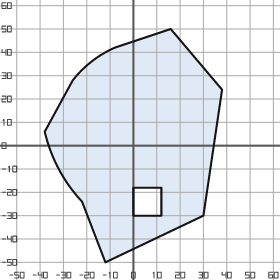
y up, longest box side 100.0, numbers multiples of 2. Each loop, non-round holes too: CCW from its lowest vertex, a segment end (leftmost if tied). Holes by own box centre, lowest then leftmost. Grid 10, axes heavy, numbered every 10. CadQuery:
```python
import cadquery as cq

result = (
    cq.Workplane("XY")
    .moveTo(-12.0, -50.0)
    .lineTo(30.0, -30.0)
    .lineTo(38.0, 24.0)
    .lineTo(16.0, 50.0)
    .lineTo(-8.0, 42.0)
    .threePointArc((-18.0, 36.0), (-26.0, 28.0))
    .lineTo(-38.0, 6.0)
    .threePointArc((-32.0, -10.0), (-22.0, -24.0))
    .close()
    .moveTo(0.0, -30.0)
    .lineTo(12.0, -30.0)
    .lineTo(12.0, -18.0)
    .lineTo(0.0, -18.0)
    .close()
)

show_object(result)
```